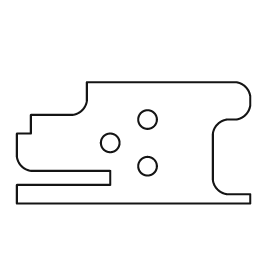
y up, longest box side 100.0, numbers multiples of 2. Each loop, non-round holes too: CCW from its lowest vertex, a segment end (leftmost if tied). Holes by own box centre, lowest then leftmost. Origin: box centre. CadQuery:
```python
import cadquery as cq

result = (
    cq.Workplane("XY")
    .moveTo(-50.0, -26.0)
    .lineTo(50.0, -26.0)
    .lineTo(50.0, -22.0)
    .lineTo(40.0, -22.0)
    .threePointArc((36.0, -20.0), (34.0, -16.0))
    .lineTo(34.0, 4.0)
    .threePointArc((36.0, 8.0), (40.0, 10.0))
    .lineTo(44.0, 10.0)
    .threePointArc((48.0, 12.0), (50.0, 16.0))
    .lineTo(50.0, 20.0)
    .threePointArc((48.0, 24.0), (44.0, 26.0))
    .lineTo(-20.0, 26.0)
    .lineTo(-20.0, 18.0)
    .threePointArc((-22.0, 14.0), (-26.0, 12.0))
    .lineTo(-44.0, 12.0)
    .lineTo(-44.0, 4.0)
    .lineTo(-50.0, 4.0)
    .lineTo(-50.0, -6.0)
    .threePointArc((-48.0, -10.0), (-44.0, -12.0))
    .lineTo(-10.0, -12.0)
    .lineTo(-10.0, -18.0)
    .lineTo(-50.0, -18.0)
    .close()
    .moveTo(6.0, -10.0)
    .circle(4.0)
    .moveTo(-10.0, 0.0)
    .circle(4.0)
    .moveTo(6.0, 10.0)
    .circle(4.0)
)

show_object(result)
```